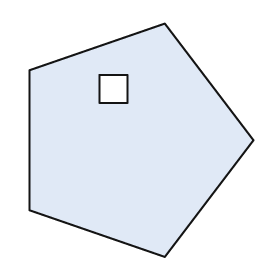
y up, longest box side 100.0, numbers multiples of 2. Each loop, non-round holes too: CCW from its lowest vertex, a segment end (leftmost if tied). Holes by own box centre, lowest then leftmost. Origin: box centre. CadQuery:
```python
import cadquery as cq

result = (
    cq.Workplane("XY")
    .moveTo(10.0, -50.0)
    .lineTo(48.0, 0.0)
    .lineTo(10.0, 50.0)
    .lineTo(-48.0, 30.0)
    .lineTo(-48.0, -30.0)
    .close()
    .moveTo(-18.0, 16.0)
    .lineTo(-6.0, 16.0)
    .lineTo(-6.0, 28.0)
    .lineTo(-18.0, 28.0)
    .close()
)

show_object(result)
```